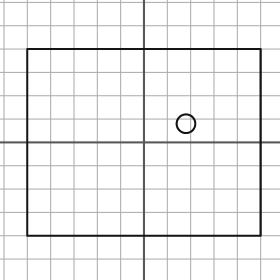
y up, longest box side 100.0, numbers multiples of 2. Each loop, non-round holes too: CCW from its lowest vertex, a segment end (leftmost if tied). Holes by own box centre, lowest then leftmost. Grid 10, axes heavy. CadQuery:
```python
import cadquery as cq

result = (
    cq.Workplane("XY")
    .moveTo(-50.0, -40.0)
    .lineTo(50.0, -40.0)
    .lineTo(50.0, 40.0)
    .lineTo(-50.0, 40.0)
    .close()
    .moveTo(18.0, 8.0)
    .circle(4.0)
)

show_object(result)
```